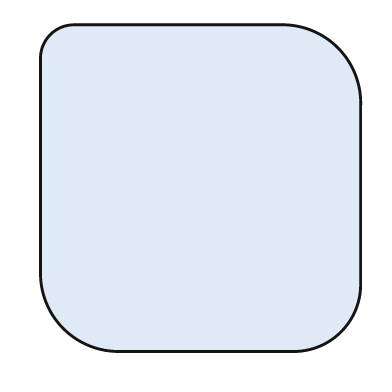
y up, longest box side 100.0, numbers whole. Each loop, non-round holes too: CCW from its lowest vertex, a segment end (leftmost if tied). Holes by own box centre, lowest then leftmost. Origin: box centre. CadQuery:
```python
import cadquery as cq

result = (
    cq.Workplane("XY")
    .moveTo(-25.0, -50.0)
    .lineTo(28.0, -50.0)
    .threePointArc((43.0, -44.0), (49.0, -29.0))
    .lineTo(49.0, 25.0)
    .threePointArc((42.0, 43.0), (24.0, 50.0))
    .lineTo(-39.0, 50.0)
    .threePointArc((-46.0, 47.0), (-49.0, 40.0))
    .lineTo(-49.0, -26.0)
    .threePointArc((-42.0, -43.0), (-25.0, -50.0))
    .close()
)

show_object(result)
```